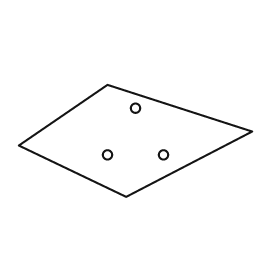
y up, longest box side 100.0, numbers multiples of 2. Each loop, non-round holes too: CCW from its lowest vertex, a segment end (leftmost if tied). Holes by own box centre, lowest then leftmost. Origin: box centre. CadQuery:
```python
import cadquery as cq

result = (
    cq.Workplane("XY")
    .moveTo(-4.0, -24.0)
    .lineTo(50.0, 4.0)
    .lineTo(-12.0, 24.0)
    .lineTo(-50.0, -2.0)
    .close()
    .moveTo(-12.0, -6.0)
    .circle(2.0)
    .moveTo(12.0, -6.0)
    .circle(2.0)
    .moveTo(0.0, 14.0)
    .circle(2.0)
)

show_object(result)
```